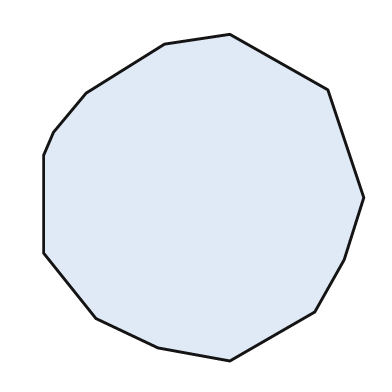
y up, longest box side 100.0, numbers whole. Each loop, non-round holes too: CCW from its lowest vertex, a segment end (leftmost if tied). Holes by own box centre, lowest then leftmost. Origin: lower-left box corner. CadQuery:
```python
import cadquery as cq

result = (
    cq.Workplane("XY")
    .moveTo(57.0, 0.0)
    .lineTo(83.0, 15.0)
    .lineTo(92.0, 31.0)
    .lineTo(98.0, 50.0)
    .lineTo(87.0, 83.0)
    .lineTo(57.0, 100.0)
    .lineTo(37.0, 97.0)
    .lineTo(13.0, 82.0)
    .lineTo(3.0, 70.0)
    .lineTo(0.0, 63.0)
    .lineTo(0.0, 33.0)
    .lineTo(16.0, 13.0)
    .lineTo(35.0, 4.0)
    .close()
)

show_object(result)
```